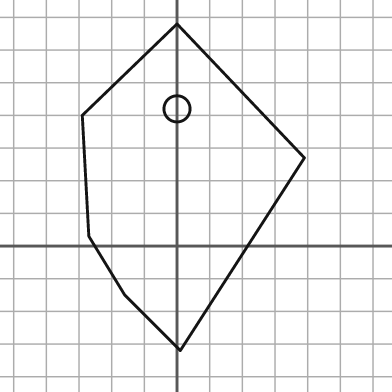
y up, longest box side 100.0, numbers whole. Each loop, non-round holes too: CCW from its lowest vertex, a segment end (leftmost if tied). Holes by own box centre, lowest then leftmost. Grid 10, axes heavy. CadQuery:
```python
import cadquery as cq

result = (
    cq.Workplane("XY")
    .moveTo(1.0, -32.0)
    .lineTo(39.0, 27.0)
    .lineTo(0.0, 68.0)
    .lineTo(-29.0, 40.0)
    .lineTo(-27.0, 3.0)
    .lineTo(-16.0, -15.0)
    .close()
    .moveTo(0.0, 42.0)
    .circle(4.0)
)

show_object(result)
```